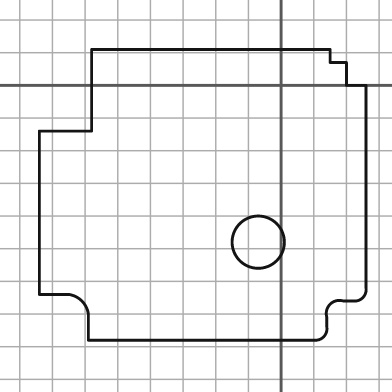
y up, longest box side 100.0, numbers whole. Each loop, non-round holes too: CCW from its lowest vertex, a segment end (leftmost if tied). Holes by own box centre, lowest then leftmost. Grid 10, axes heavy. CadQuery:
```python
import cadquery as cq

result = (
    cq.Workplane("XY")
    .moveTo(-59.0, -78.0)
    .lineTo(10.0, -78.0)
    .threePointArc((13.0, -77.0), (14.0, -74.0))
    .lineTo(14.0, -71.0)
    .threePointArc((15.0, -67.0), (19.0, -66.0))
    .lineTo(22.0, -66.0)
    .threePointArc((25.0, -65.0), (26.0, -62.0))
    .lineTo(26.0, 0.0)
    .lineTo(20.0, 0.0)
    .lineTo(20.0, 7.0)
    .lineTo(15.0, 7.0)
    .lineTo(15.0, 11.0)
    .lineTo(-58.0, 11.0)
    .lineTo(-58.0, -14.0)
    .lineTo(-74.0, -14.0)
    .lineTo(-74.0, -64.0)
    .lineTo(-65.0, -64.0)
    .threePointArc((-61.0, -66.0), (-59.0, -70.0))
    .close()
    .moveTo(-7.0, -48.0)
    .circle(8.0)
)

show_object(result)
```